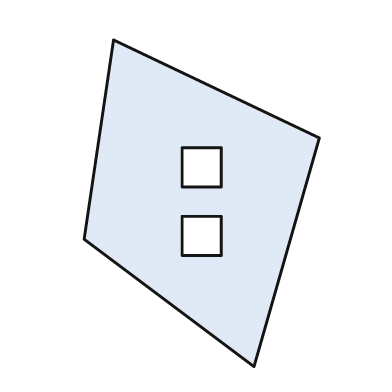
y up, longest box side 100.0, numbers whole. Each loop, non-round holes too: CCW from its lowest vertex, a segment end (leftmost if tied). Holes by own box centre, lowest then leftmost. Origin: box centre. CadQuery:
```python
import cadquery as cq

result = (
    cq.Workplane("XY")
    .moveTo(16.0, -50.0)
    .lineTo(36.0, 20.0)
    .lineTo(-27.0, 50.0)
    .lineTo(-36.0, -11.0)
    .close()
    .moveTo(-6.0, -16.0)
    .lineTo(6.0, -16.0)
    .lineTo(6.0, -4.0)
    .lineTo(-6.0, -4.0)
    .close()
    .moveTo(-6.0, 5.0)
    .lineTo(6.0, 5.0)
    .lineTo(6.0, 17.0)
    .lineTo(-6.0, 17.0)
    .close()
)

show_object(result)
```